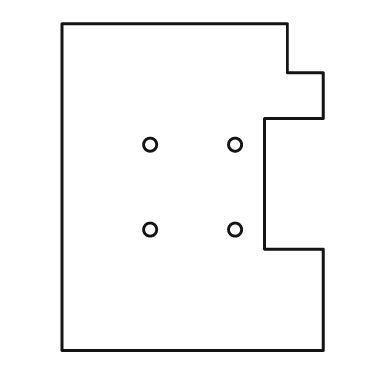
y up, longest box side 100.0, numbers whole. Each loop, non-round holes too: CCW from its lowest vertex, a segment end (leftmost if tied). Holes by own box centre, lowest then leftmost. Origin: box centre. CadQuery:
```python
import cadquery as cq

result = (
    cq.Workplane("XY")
    .moveTo(-40.0, -50.0)
    .lineTo(40.0, -50.0)
    .lineTo(40.0, -19.0)
    .lineTo(22.0, -19.0)
    .lineTo(22.0, 21.0)
    .lineTo(40.0, 21.0)
    .lineTo(40.0, 35.0)
    .lineTo(29.0, 35.0)
    .lineTo(29.0, 50.0)
    .lineTo(-40.0, 50.0)
    .close()
    .moveTo(-13.0, -13.0)
    .circle(2.0)
    .moveTo(13.0, -13.0)
    .circle(2.0)
    .moveTo(-13.0, 13.0)
    .circle(2.0)
    .moveTo(13.0, 13.0)
    .circle(2.0)
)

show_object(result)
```